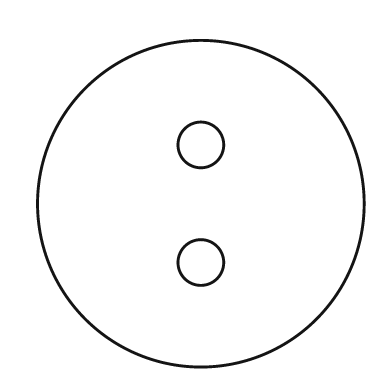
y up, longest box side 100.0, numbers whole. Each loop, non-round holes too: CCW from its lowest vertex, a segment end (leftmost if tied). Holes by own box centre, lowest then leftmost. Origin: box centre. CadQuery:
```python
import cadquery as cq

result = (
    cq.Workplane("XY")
    .moveTo(0.0, 0.0)
    .circle(50.0)
    .moveTo(0.0, -18.0)
    .circle(7.0)
    .moveTo(0.0, 18.0)
    .circle(7.0)
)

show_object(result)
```